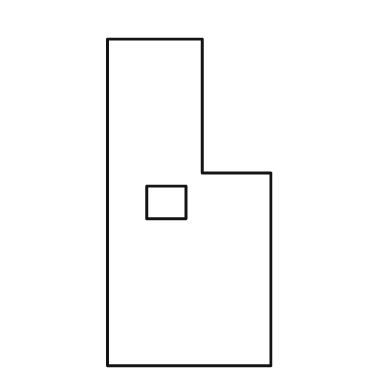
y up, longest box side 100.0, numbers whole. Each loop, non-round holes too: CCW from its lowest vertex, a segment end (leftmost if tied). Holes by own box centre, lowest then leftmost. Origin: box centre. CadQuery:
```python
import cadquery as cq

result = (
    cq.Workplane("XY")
    .moveTo(-25.0, -50.0)
    .lineTo(25.0, -50.0)
    .lineTo(25.0, 9.0)
    .lineTo(4.0, 9.0)
    .lineTo(4.0, 50.0)
    .lineTo(-25.0, 50.0)
    .close()
    .moveTo(-13.0, -5.0)
    .lineTo(-1.0, -5.0)
    .lineTo(-1.0, 5.0)
    .lineTo(-13.0, 5.0)
    .close()
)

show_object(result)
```